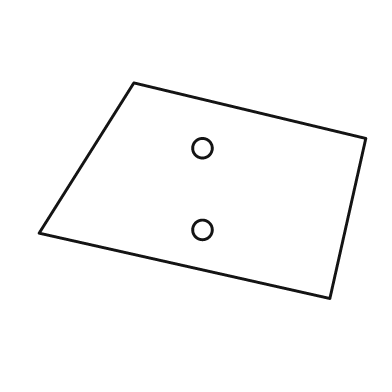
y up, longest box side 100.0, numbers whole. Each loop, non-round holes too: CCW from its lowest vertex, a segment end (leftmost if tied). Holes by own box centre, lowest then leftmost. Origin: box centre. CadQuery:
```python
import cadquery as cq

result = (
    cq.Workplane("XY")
    .moveTo(39.0, -33.0)
    .lineTo(50.0, 16.0)
    .lineTo(-21.0, 33.0)
    .lineTo(-50.0, -13.0)
    .close()
    .moveTo(0.0, -12.0)
    .circle(3.0)
    .moveTo(0.0, 13.0)
    .circle(3.0)
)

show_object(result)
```